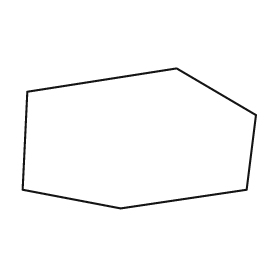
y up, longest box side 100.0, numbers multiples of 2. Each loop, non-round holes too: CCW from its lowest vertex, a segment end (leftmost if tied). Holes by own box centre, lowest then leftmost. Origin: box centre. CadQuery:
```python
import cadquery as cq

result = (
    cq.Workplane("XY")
    .moveTo(-8.0, -30.0)
    .lineTo(46.0, -22.0)
    .lineTo(50.0, 10.0)
    .lineTo(16.0, 30.0)
    .lineTo(-48.0, 20.0)
    .lineTo(-50.0, -22.0)
    .close()
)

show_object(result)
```